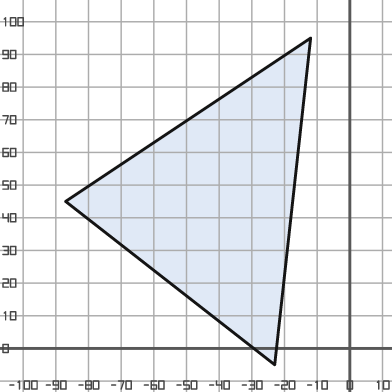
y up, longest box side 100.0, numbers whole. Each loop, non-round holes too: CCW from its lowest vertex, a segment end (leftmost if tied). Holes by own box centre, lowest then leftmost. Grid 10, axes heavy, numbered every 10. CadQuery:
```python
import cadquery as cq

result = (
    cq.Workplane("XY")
    .moveTo(-23.0, -5.0)
    .lineTo(-12.0, 95.0)
    .lineTo(-87.0, 45.0)
    .close()
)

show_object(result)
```